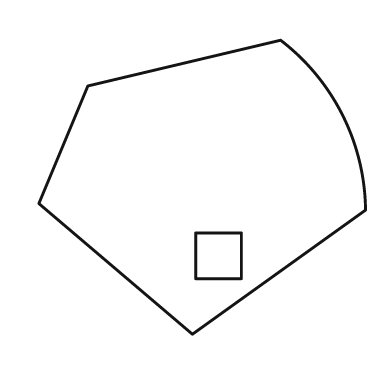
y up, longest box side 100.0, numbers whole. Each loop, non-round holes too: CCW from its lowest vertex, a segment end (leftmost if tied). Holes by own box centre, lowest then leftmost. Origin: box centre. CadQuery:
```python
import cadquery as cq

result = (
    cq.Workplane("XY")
    .moveTo(-3.0, -45.0)
    .lineTo(50.0, -7.0)
    .threePointArc((43.0, 22.0), (24.0, 45.0))
    .lineTo(-35.0, 31.0)
    .lineTo(-50.0, -5.0)
    .close()
    .moveTo(-2.0, -28.0)
    .lineTo(12.0, -28.0)
    .lineTo(12.0, -14.0)
    .lineTo(-2.0, -14.0)
    .close()
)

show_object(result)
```